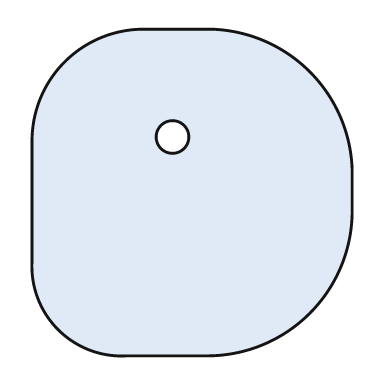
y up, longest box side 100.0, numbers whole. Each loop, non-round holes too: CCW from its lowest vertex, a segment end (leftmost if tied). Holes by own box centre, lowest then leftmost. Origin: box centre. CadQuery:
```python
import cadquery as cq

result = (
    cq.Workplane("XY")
    .moveTo(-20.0, -50.0)
    .lineTo(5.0, -50.0)
    .threePointArc((36.0, -37.0), (49.0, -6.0))
    .lineTo(49.0, 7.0)
    .threePointArc((36.0, 37.0), (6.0, 50.0))
    .lineTo(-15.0, 50.0)
    .threePointArc((-39.0, 40.0), (-49.0, 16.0))
    .lineTo(-49.0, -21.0)
    .threePointArc((-41.0, -42.0), (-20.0, -50.0))
    .close()
    .moveTo(-6.0, 17.0)
    .circle(5.0)
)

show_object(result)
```